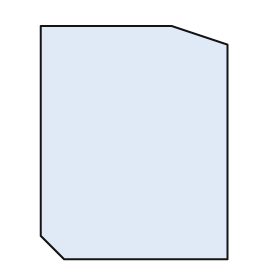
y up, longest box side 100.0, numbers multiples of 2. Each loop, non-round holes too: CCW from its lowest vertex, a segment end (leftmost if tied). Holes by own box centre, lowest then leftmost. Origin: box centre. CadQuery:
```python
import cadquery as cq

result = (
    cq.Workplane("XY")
    .moveTo(-30.0, -50.0)
    .lineTo(40.0, -50.0)
    .lineTo(40.0, 42.0)
    .lineTo(16.0, 50.0)
    .lineTo(-40.0, 50.0)
    .lineTo(-40.0, -40.0)
    .close()
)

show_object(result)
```